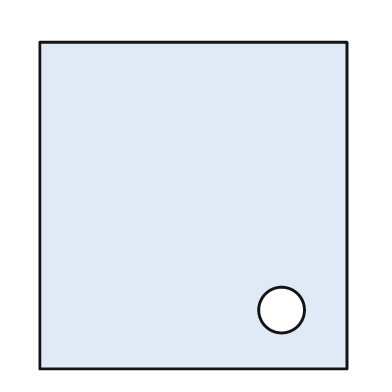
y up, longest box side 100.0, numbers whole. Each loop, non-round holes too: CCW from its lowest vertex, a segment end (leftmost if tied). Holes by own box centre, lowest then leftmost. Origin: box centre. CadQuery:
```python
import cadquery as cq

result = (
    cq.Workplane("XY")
    .moveTo(-47.0, -50.0)
    .lineTo(47.0, -50.0)
    .lineTo(47.0, 50.0)
    .lineTo(-47.0, 50.0)
    .close()
    .moveTo(27.0, -32.0)
    .circle(7.0)
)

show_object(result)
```